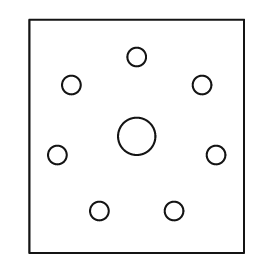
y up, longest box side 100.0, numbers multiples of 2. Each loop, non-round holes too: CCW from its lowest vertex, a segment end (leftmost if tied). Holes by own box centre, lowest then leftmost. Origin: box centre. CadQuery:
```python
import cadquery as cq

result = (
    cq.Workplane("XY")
    .moveTo(-46.0, -50.0)
    .lineTo(46.0, -50.0)
    .lineTo(46.0, 50.0)
    .lineTo(-46.0, 50.0)
    .close()
    .moveTo(-16.0, -32.0)
    .circle(4.0)
    .moveTo(16.0, -32.0)
    .circle(4.0)
    .moveTo(-34.0, -8.0)
    .circle(4.0)
    .moveTo(34.0, -8.0)
    .circle(4.0)
    .moveTo(0.0, 0.0)
    .circle(8.0)
    .moveTo(-28.0, 22.0)
    .circle(4.0)
    .moveTo(28.0, 22.0)
    .circle(4.0)
    .moveTo(0.0, 34.0)
    .circle(4.0)
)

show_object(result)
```